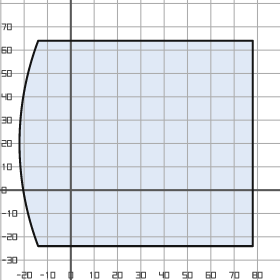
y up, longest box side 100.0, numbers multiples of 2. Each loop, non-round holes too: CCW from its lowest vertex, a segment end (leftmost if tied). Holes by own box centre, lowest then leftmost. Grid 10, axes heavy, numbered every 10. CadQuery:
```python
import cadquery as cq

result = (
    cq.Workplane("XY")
    .moveTo(-14.0, -24.0)
    .lineTo(78.0, -24.0)
    .lineTo(78.0, 64.0)
    .lineTo(-14.0, 64.0)
    .threePointArc((-22.0, 20.0), (-14.0, -24.0))
    .close()
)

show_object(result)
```